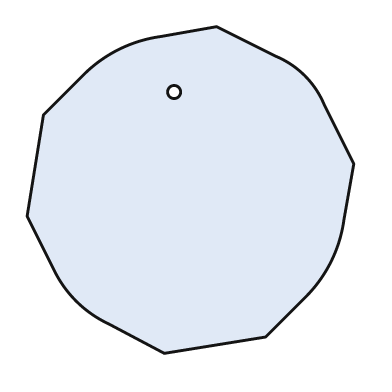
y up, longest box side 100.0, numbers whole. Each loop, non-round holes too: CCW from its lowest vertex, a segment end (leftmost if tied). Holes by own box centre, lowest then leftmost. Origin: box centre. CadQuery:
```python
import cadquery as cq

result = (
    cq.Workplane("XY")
    .moveTo(-8.0, -50.0)
    .lineTo(23.0, -45.0)
    .lineTo(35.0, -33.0)
    .threePointArc((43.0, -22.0), (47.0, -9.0))
    .lineTo(50.0, 8.0)
    .lineTo(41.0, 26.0)
    .threePointArc((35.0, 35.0), (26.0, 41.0))
    .lineTo(8.0, 50.0)
    .lineTo(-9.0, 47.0)
    .threePointArc((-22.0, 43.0), (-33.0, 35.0))
    .lineTo(-45.0, 23.0)
    .lineTo(-50.0, -8.0)
    .lineTo(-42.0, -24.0)
    .threePointArc((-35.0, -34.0), (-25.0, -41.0))
    .close()
    .moveTo(-5.0, 30.0)
    .circle(2.0)
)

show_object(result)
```